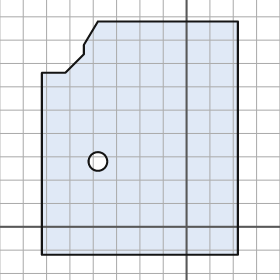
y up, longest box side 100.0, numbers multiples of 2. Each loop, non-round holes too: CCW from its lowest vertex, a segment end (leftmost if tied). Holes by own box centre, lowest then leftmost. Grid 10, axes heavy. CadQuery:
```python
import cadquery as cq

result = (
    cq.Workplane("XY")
    .moveTo(-62.0, -12.0)
    .lineTo(22.0, -12.0)
    .lineTo(22.0, 88.0)
    .lineTo(-38.0, 88.0)
    .lineTo(-44.0, 78.0)
    .lineTo(-44.0, 74.0)
    .lineTo(-52.0, 66.0)
    .lineTo(-62.0, 66.0)
    .close()
    .moveTo(-38.0, 28.0)
    .circle(4.0)
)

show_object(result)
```